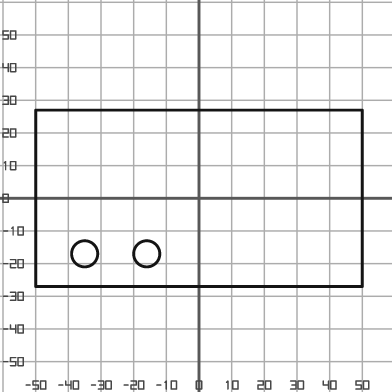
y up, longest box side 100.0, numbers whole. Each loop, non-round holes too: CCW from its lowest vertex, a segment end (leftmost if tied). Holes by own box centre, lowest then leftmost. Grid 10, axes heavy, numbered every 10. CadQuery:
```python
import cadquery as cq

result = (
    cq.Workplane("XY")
    .moveTo(-50.0, -27.0)
    .lineTo(50.0, -27.0)
    .lineTo(50.0, 27.0)
    .lineTo(-50.0, 27.0)
    .close()
    .moveTo(-35.0, -17.0)
    .circle(4.0)
    .moveTo(-16.0, -17.0)
    .circle(4.0)
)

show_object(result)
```